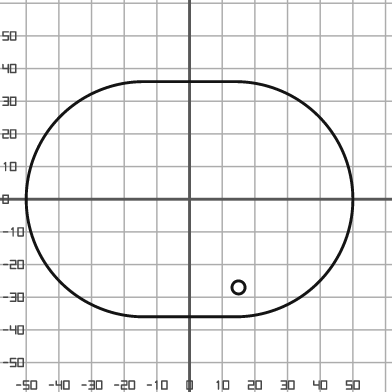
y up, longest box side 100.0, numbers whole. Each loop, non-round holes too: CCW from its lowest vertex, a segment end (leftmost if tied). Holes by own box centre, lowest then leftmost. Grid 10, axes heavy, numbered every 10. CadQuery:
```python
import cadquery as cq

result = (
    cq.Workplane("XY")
    .moveTo(-14.0, -36.0)
    .lineTo(14.0, -36.0)
    .threePointArc((50.0, 0.0), (14.0, 36.0))
    .lineTo(-14.0, 36.0)
    .threePointArc((-50.0, 0.0), (-14.0, -36.0))
    .close()
    .moveTo(15.0, -27.0)
    .circle(2.0)
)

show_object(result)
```